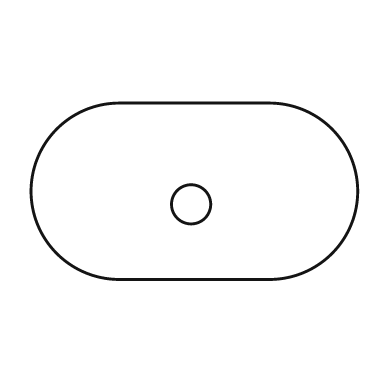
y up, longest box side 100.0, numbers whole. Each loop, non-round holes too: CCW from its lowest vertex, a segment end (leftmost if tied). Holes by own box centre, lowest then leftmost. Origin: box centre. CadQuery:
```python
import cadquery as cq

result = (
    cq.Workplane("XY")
    .moveTo(-23.0, -27.0)
    .lineTo(23.0, -27.0)
    .threePointArc((50.0, 0.0), (23.0, 27.0))
    .lineTo(-23.0, 27.0)
    .threePointArc((-50.0, 0.0), (-23.0, -27.0))
    .close()
    .moveTo(-1.0, -4.0)
    .circle(6.0)
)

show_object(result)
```